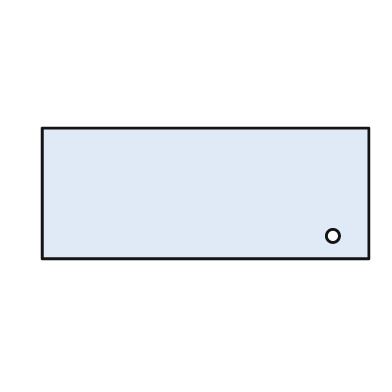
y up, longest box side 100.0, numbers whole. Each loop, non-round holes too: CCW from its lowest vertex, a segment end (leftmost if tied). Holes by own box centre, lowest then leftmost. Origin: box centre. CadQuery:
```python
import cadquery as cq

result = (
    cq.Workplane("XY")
    .moveTo(-50.0, -20.0)
    .lineTo(50.0, -20.0)
    .lineTo(50.0, 20.0)
    .lineTo(-50.0, 20.0)
    .close()
    .moveTo(39.0, -13.0)
    .circle(2.0)
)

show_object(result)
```